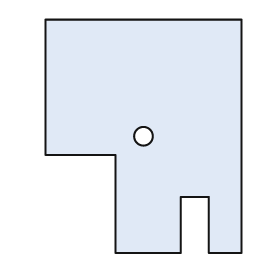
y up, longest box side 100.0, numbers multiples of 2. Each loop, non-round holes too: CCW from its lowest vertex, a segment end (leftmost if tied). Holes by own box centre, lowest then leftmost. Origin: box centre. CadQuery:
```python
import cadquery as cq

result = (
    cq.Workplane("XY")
    .moveTo(-12.0, -50.0)
    .lineTo(16.0, -50.0)
    .lineTo(16.0, -26.0)
    .lineTo(28.0, -26.0)
    .lineTo(28.0, -50.0)
    .lineTo(42.0, -50.0)
    .lineTo(42.0, 50.0)
    .lineTo(-42.0, 50.0)
    .lineTo(-42.0, -8.0)
    .lineTo(-12.0, -8.0)
    .close()
    .moveTo(0.0, 0.0)
    .circle(4.0)
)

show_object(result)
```